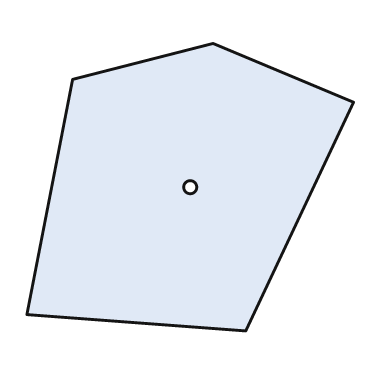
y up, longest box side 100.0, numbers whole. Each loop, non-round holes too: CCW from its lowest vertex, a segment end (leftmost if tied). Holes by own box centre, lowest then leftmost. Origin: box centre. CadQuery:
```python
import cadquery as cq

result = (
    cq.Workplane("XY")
    .moveTo(17.0, -44.0)
    .lineTo(50.0, 26.0)
    .lineTo(7.0, 44.0)
    .lineTo(-36.0, 33.0)
    .lineTo(-50.0, -39.0)
    .close()
    .moveTo(0.0, 0.0)
    .circle(2.0)
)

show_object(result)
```